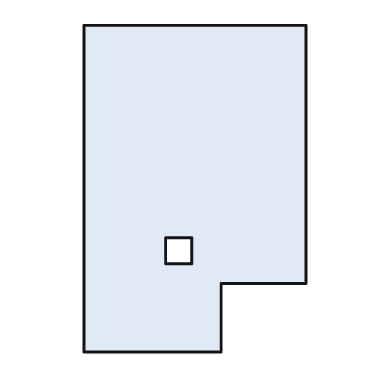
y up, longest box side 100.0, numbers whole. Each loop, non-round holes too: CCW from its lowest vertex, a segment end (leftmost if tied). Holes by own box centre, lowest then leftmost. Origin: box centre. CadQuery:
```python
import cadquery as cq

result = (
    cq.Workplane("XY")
    .moveTo(-34.0, -50.0)
    .lineTo(8.0, -50.0)
    .lineTo(8.0, -29.0)
    .lineTo(34.0, -29.0)
    .lineTo(34.0, 50.0)
    .lineTo(-34.0, 50.0)
    .close()
    .moveTo(-9.0, -23.0)
    .lineTo(-1.0, -23.0)
    .lineTo(-1.0, -15.0)
    .lineTo(-9.0, -15.0)
    .close()
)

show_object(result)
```